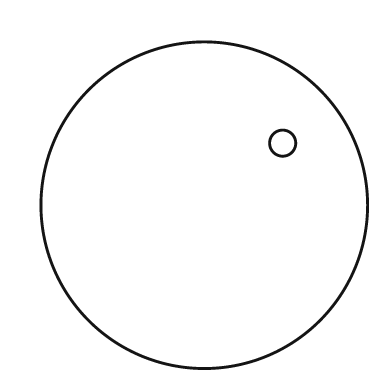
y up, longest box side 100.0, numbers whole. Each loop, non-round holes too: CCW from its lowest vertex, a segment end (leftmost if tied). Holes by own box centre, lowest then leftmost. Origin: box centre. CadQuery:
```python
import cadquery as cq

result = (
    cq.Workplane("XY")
    .moveTo(0.0, 0.0)
    .circle(50.0)
    .moveTo(24.0, 19.0)
    .circle(4.0)
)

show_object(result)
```